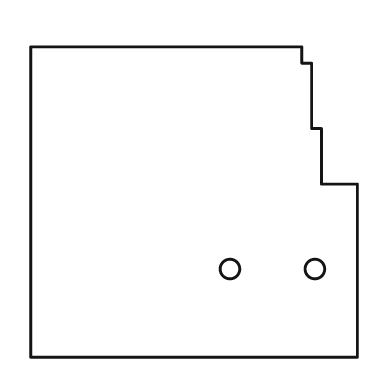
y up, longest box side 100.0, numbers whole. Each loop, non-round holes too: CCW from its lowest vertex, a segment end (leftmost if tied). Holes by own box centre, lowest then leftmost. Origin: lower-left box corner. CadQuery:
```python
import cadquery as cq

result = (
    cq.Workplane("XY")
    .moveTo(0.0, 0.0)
    .lineTo(100.0, 0.0)
    .lineTo(100.0, 53.0)
    .lineTo(89.0, 53.0)
    .lineTo(89.0, 70.0)
    .lineTo(86.0, 70.0)
    .lineTo(86.0, 90.0)
    .lineTo(83.0, 90.0)
    .lineTo(83.0, 95.0)
    .lineTo(0.0, 95.0)
    .close()
    .moveTo(61.0, 27.0)
    .circle(3.0)
    .moveTo(87.0, 27.0)
    .circle(3.0)
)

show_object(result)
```